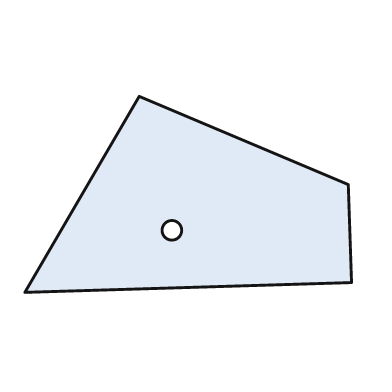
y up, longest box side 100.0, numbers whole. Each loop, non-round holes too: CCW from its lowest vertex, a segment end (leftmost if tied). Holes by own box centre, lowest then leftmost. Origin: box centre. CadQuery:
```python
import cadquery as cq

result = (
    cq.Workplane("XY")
    .moveTo(-50.0, -30.0)
    .lineTo(50.0, -27.0)
    .lineTo(49.0, 3.0)
    .lineTo(-15.0, 30.0)
    .close()
    .moveTo(-5.0, -11.0)
    .circle(3.0)
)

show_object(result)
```